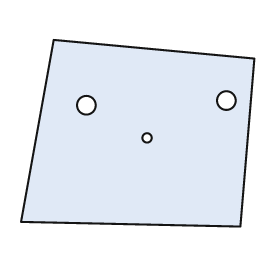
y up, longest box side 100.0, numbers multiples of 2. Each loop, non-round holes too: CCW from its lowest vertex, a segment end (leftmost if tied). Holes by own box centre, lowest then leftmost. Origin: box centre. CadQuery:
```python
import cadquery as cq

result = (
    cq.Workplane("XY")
    .moveTo(44.0, -40.0)
    .lineTo(50.0, 32.0)
    .lineTo(-36.0, 40.0)
    .lineTo(-50.0, -38.0)
    .close()
    .moveTo(4.0, -2.0)
    .circle(2.0)
    .moveTo(-22.0, 12.0)
    .circle(4.0)
    .moveTo(38.0, 14.0)
    .circle(4.0)
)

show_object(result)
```